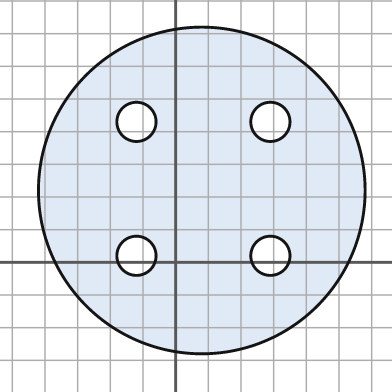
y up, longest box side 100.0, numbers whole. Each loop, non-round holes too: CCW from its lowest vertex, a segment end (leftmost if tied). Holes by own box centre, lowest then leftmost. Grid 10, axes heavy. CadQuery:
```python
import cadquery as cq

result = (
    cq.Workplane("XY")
    .moveTo(8.0, 22.0)
    .circle(50.0)
    .moveTo(-12.0, 2.0)
    .circle(6.0)
    .moveTo(29.0, 2.0)
    .circle(6.0)
    .moveTo(-12.0, 43.0)
    .circle(6.0)
    .moveTo(29.0, 43.0)
    .circle(6.0)
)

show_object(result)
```